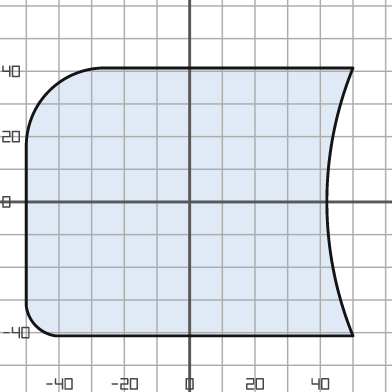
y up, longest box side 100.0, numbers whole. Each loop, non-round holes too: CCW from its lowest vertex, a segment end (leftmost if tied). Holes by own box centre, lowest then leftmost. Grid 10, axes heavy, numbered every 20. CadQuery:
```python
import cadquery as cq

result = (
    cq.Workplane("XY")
    .moveTo(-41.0, -41.0)
    .lineTo(50.0, -41.0)
    .threePointArc((42.0, 0.0), (50.0, 41.0))
    .lineTo(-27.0, 41.0)
    .threePointArc((-43.0, 34.0), (-50.0, 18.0))
    .lineTo(-50.0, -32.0)
    .threePointArc((-47.0, -38.0), (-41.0, -41.0))
    .close()
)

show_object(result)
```